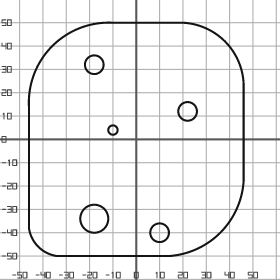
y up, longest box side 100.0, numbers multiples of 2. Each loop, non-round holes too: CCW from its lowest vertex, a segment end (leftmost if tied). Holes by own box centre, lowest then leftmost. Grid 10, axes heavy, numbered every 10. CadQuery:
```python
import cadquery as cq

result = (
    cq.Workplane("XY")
    .moveTo(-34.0, -50.0)
    .lineTo(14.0, -50.0)
    .threePointArc((36.0, -40.0), (46.0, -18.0))
    .lineTo(46.0, 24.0)
    .threePointArc((38.0, 42.0), (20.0, 50.0))
    .lineTo(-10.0, 50.0)
    .threePointArc((-36.0, 40.0), (-46.0, 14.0))
    .lineTo(-46.0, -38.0)
    .threePointArc((-42.0, -46.0), (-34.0, -50.0))
    .close()
    .moveTo(10.0, -40.0)
    .circle(4.0)
    .moveTo(-18.0, -34.0)
    .circle(6.0)
    .moveTo(-10.0, 4.0)
    .circle(2.0)
    .moveTo(22.0, 12.0)
    .circle(4.0)
    .moveTo(-18.0, 32.0)
    .circle(4.0)
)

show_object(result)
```